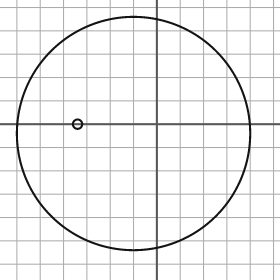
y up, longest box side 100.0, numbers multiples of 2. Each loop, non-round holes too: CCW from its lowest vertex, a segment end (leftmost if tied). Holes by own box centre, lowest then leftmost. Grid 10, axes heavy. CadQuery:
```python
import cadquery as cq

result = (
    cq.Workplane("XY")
    .moveTo(-10.0, -4.0)
    .circle(50.0)
    .moveTo(-34.0, 0.0)
    .circle(2.0)
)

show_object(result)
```